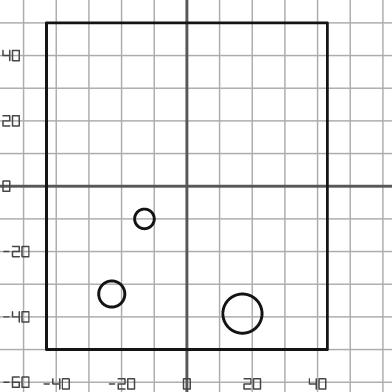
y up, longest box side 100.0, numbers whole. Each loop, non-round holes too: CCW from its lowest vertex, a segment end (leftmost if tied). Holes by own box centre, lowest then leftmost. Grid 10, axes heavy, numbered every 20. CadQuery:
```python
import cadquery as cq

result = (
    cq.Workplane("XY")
    .moveTo(-43.0, -50.0)
    .lineTo(43.0, -50.0)
    .lineTo(43.0, 50.0)
    .lineTo(-43.0, 50.0)
    .close()
    .moveTo(17.0, -39.0)
    .circle(6.0)
    .moveTo(-23.0, -33.0)
    .circle(4.0)
    .moveTo(-13.0, -10.0)
    .circle(3.0)
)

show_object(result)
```